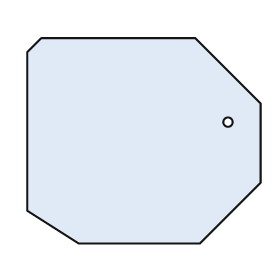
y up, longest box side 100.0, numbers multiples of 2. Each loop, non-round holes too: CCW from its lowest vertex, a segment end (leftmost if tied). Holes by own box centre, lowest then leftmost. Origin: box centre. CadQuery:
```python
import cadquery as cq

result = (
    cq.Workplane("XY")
    .moveTo(-28.0, -44.0)
    .lineTo(24.0, -44.0)
    .lineTo(50.0, -18.0)
    .lineTo(50.0, 16.0)
    .lineTo(22.0, 44.0)
    .lineTo(-44.0, 44.0)
    .lineTo(-50.0, 38.0)
    .lineTo(-50.0, -30.0)
    .close()
    .moveTo(36.0, 8.0)
    .circle(2.0)
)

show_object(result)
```